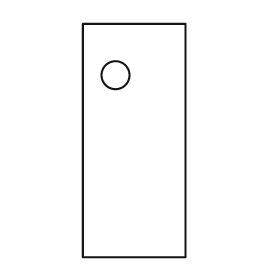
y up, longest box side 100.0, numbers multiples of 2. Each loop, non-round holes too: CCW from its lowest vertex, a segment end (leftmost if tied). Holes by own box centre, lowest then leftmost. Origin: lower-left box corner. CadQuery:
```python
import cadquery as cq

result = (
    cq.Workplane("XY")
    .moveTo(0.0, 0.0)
    .lineTo(44.0, 0.0)
    .lineTo(44.0, 100.0)
    .lineTo(0.0, 100.0)
    .close()
    .moveTo(14.0, 78.0)
    .circle(6.0)
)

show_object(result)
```